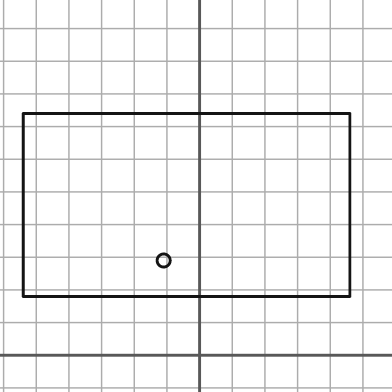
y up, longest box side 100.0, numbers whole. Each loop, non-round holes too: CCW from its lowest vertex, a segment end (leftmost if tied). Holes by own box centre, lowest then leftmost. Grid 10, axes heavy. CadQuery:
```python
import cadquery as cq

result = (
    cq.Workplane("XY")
    .moveTo(-54.0, 18.0)
    .lineTo(46.0, 18.0)
    .lineTo(46.0, 74.0)
    .lineTo(-54.0, 74.0)
    .close()
    .moveTo(-11.0, 29.0)
    .circle(2.0)
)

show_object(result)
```